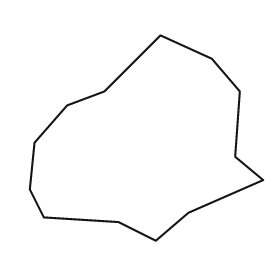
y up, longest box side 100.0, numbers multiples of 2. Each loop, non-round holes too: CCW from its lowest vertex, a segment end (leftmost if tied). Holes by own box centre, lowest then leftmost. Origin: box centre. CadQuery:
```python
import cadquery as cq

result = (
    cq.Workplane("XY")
    .moveTo(4.0, -44.0)
    .lineTo(18.0, -32.0)
    .lineTo(50.0, -18.0)
    .lineTo(38.0, -8.0)
    .lineTo(40.0, 20.0)
    .lineTo(28.0, 34.0)
    .lineTo(6.0, 44.0)
    .lineTo(-18.0, 20.0)
    .lineTo(-34.0, 14.0)
    .lineTo(-48.0, -2.0)
    .lineTo(-50.0, -22.0)
    .lineTo(-44.0, -34.0)
    .lineTo(-12.0, -36.0)
    .close()
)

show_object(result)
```